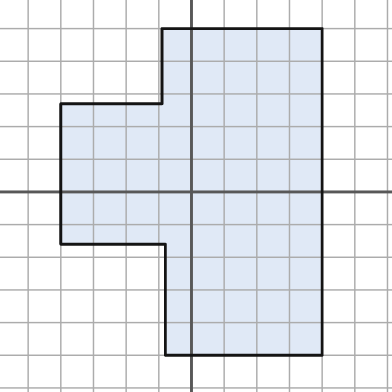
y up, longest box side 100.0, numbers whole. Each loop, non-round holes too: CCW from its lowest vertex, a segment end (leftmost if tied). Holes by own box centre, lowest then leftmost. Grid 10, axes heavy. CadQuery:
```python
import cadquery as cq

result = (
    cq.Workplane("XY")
    .moveTo(-8.0, -50.0)
    .lineTo(40.0, -50.0)
    .lineTo(40.0, 50.0)
    .lineTo(-9.0, 50.0)
    .lineTo(-9.0, 27.0)
    .lineTo(-40.0, 27.0)
    .lineTo(-40.0, -16.0)
    .lineTo(-8.0, -16.0)
    .close()
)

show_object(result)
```